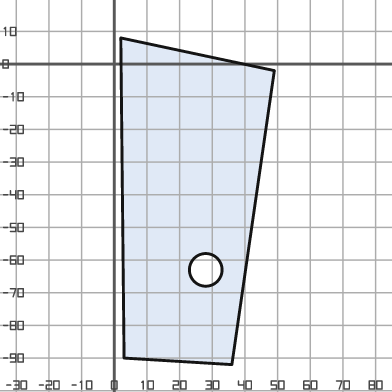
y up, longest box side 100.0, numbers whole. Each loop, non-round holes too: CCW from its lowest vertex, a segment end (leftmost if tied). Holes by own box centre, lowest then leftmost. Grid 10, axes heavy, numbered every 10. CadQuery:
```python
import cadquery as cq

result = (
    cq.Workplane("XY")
    .moveTo(36.0, -92.0)
    .lineTo(49.0, -2.0)
    .lineTo(2.0, 8.0)
    .lineTo(3.0, -90.0)
    .close()
    .moveTo(28.0, -63.0)
    .circle(5.0)
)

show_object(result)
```